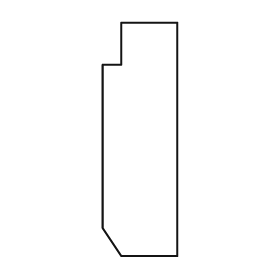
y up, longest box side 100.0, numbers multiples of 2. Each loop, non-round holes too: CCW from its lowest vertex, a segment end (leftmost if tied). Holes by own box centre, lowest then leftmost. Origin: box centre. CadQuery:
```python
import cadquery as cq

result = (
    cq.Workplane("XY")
    .moveTo(-8.0, -50.0)
    .lineTo(16.0, -50.0)
    .lineTo(16.0, 50.0)
    .lineTo(-8.0, 50.0)
    .lineTo(-8.0, 32.0)
    .lineTo(-16.0, 32.0)
    .lineTo(-16.0, -38.0)
    .close()
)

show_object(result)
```